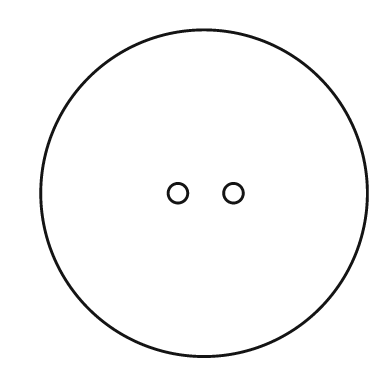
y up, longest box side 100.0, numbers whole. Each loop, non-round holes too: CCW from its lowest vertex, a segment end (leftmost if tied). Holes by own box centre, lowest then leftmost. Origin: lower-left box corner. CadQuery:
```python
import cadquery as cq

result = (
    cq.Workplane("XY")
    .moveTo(50.0, 50.0)
    .circle(50.0)
    .moveTo(42.0, 50.0)
    .circle(3.0)
    .moveTo(59.0, 50.0)
    .circle(3.0)
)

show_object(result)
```